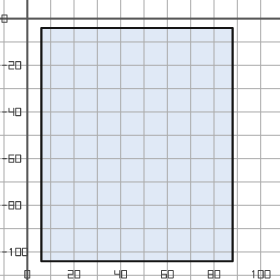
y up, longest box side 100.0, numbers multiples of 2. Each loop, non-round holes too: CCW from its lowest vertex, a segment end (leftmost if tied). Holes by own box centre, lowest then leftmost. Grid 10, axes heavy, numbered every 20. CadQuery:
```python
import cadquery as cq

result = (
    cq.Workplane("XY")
    .moveTo(6.0, -104.0)
    .lineTo(88.0, -104.0)
    .lineTo(88.0, -4.0)
    .lineTo(6.0, -4.0)
    .close()
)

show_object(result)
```